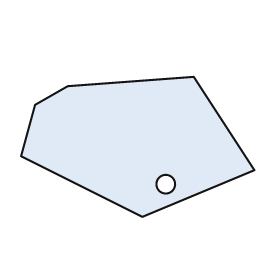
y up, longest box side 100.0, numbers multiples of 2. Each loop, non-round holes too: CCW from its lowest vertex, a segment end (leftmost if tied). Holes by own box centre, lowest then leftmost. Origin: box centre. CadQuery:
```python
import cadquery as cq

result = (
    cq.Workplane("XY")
    .moveTo(2.0, -30.0)
    .lineTo(50.0, -10.0)
    .lineTo(24.0, 30.0)
    .lineTo(-30.0, 26.0)
    .lineTo(-44.0, 18.0)
    .lineTo(-50.0, -4.0)
    .close()
    .moveTo(12.0, -16.0)
    .circle(4.0)
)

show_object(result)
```